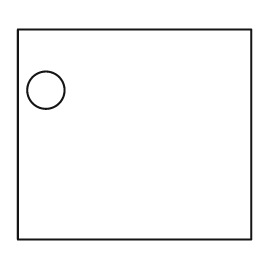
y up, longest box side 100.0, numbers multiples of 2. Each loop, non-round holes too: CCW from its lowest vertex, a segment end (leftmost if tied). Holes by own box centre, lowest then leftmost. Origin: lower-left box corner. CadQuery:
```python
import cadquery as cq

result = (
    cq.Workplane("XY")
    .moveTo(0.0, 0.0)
    .lineTo(100.0, 0.0)
    .lineTo(100.0, 90.0)
    .lineTo(0.0, 90.0)
    .close()
    .moveTo(12.0, 64.0)
    .circle(8.0)
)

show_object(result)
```